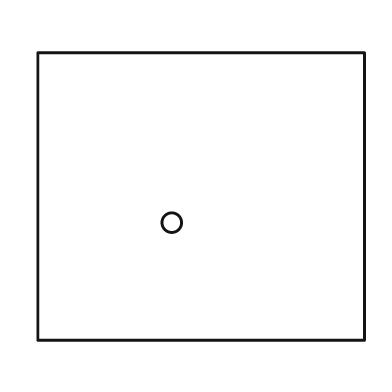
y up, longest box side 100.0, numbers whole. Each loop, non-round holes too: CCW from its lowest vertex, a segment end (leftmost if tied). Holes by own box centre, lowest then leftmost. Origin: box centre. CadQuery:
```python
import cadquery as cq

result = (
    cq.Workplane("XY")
    .moveTo(-50.0, -44.0)
    .lineTo(50.0, -44.0)
    .lineTo(50.0, 44.0)
    .lineTo(-50.0, 44.0)
    .close()
    .moveTo(-9.0, -8.0)
    .circle(3.0)
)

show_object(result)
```